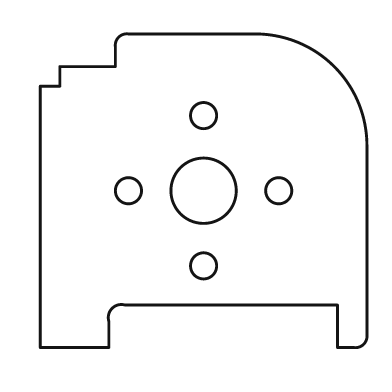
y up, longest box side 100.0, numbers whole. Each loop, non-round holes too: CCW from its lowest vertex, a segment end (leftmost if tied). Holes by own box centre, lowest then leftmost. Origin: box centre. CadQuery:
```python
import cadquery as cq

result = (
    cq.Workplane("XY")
    .moveTo(-50.0, -48.0)
    .lineTo(-29.0, -48.0)
    .lineTo(-29.0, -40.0)
    .threePointArc((-28.0, -36.0), (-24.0, -35.0))
    .lineTo(41.0, -35.0)
    .lineTo(41.0, -48.0)
    .lineTo(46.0, -48.0)
    .threePointArc((49.0, -47.0), (50.0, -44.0))
    .lineTo(50.0, 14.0)
    .threePointArc((40.0, 38.0), (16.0, 48.0))
    .lineTo(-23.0, 48.0)
    .threePointArc((-26.0, 47.0), (-27.0, 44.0))
    .lineTo(-27.0, 38.0)
    .lineTo(-44.0, 38.0)
    .lineTo(-44.0, 32.0)
    .lineTo(-50.0, 32.0)
    .close()
    .moveTo(0.0, -23.0)
    .circle(4.0)
    .moveTo(-23.0, 0.0)
    .circle(4.0)
    .moveTo(0.0, 0.0)
    .circle(10.0)
    .moveTo(23.0, 0.0)
    .circle(4.0)
    .moveTo(0.0, 23.0)
    .circle(4.0)
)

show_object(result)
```